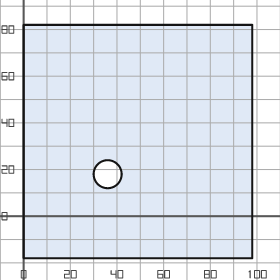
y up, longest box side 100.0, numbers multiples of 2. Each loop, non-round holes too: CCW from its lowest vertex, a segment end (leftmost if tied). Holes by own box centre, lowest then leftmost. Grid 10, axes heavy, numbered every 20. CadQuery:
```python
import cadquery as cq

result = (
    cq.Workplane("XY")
    .moveTo(0.0, -18.0)
    .lineTo(98.0, -18.0)
    .lineTo(98.0, 82.0)
    .lineTo(0.0, 82.0)
    .close()
    .moveTo(36.0, 18.0)
    .circle(6.0)
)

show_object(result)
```